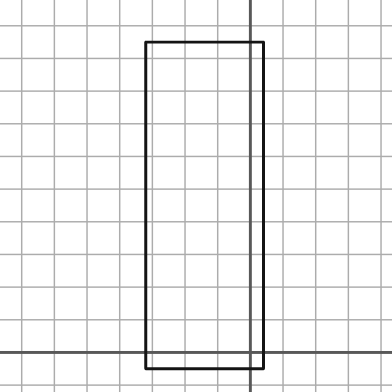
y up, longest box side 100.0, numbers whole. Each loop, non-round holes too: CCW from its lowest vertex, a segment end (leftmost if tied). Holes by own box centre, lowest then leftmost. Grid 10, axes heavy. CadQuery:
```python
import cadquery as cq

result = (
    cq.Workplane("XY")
    .moveTo(-32.0, -5.0)
    .lineTo(4.0, -5.0)
    .lineTo(4.0, 95.0)
    .lineTo(-32.0, 95.0)
    .close()
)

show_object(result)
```